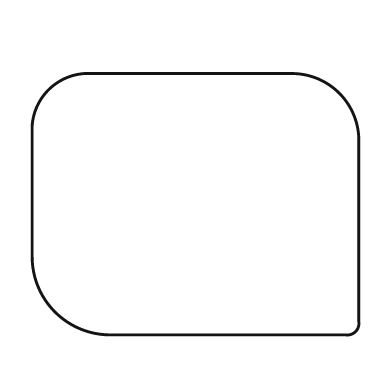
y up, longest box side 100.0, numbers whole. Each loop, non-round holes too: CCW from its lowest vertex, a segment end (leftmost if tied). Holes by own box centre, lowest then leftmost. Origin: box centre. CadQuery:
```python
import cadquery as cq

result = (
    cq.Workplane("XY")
    .moveTo(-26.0, -40.0)
    .lineTo(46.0, -40.0)
    .threePointArc((49.0, -39.0), (50.0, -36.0))
    .lineTo(50.0, 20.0)
    .threePointArc((44.0, 34.0), (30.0, 40.0))
    .lineTo(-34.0, 40.0)
    .threePointArc((-45.0, 35.0), (-50.0, 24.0))
    .lineTo(-50.0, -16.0)
    .threePointArc((-43.0, -33.0), (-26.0, -40.0))
    .close()
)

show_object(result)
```